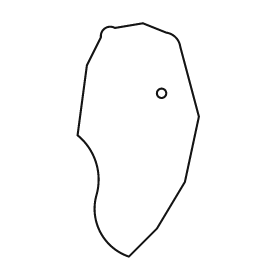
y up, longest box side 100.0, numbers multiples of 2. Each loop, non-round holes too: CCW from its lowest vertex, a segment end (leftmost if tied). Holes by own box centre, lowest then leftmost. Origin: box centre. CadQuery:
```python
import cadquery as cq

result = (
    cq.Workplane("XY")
    .moveTo(-4.0, -50.0)
    .lineTo(8.0, -38.0)
    .lineTo(20.0, -18.0)
    .lineTo(26.0, 10.0)
    .lineTo(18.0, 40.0)
    .threePointArc((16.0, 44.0), (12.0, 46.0))
    .lineTo(2.0, 50.0)
    .lineTo(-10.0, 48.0)
    .threePointArc((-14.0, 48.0), (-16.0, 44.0))
    .lineTo(-22.0, 32.0)
    .lineTo(-26.0, 2.0)
    .threePointArc((-18.0, -10.0), (-18.0, -24.0))
    .threePointArc((-16.0, -40.0), (-4.0, -50.0))
    .close()
    .moveTo(10.0, 20.0)
    .circle(2.0)
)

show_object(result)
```